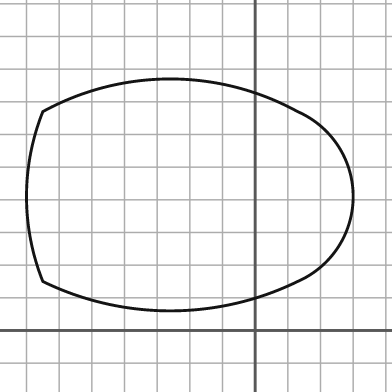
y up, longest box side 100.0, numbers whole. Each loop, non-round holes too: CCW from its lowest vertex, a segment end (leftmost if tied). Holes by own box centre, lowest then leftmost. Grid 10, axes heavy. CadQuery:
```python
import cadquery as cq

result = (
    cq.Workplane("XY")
    .moveTo(-65.0, 15.0)
    .threePointArc((-26.0, 6.0), (13.0, 15.0))
    .threePointArc((30.0, 41.0), (13.0, 67.0))
    .threePointArc((-26.0, 77.0), (-65.0, 67.0))
    .threePointArc((-70.0, 41.0), (-65.0, 15.0))
    .close()
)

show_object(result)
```